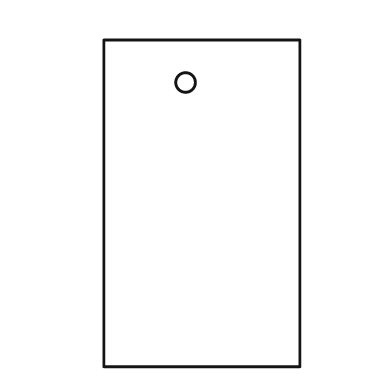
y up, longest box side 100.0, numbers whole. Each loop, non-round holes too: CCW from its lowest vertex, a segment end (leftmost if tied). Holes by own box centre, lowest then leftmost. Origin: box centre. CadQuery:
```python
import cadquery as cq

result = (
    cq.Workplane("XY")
    .moveTo(-30.0, -50.0)
    .lineTo(30.0, -50.0)
    .lineTo(30.0, 50.0)
    .lineTo(-30.0, 50.0)
    .close()
    .moveTo(-5.0, 37.0)
    .circle(3.0)
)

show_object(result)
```